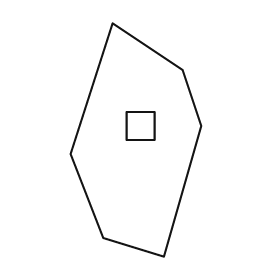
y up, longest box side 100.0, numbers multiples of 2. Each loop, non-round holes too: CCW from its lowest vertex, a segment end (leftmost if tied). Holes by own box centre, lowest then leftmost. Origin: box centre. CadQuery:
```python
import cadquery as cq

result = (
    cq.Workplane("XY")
    .moveTo(12.0, -50.0)
    .lineTo(28.0, 6.0)
    .lineTo(20.0, 30.0)
    .lineTo(-10.0, 50.0)
    .lineTo(-28.0, -6.0)
    .lineTo(-14.0, -42.0)
    .close()
    .moveTo(-4.0, 0.0)
    .lineTo(8.0, 0.0)
    .lineTo(8.0, 12.0)
    .lineTo(-4.0, 12.0)
    .close()
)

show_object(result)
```